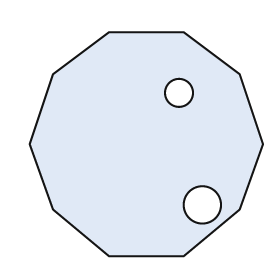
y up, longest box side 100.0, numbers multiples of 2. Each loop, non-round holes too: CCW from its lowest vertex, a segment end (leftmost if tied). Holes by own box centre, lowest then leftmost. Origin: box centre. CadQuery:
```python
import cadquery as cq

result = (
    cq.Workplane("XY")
    .moveTo(-16.0, -48.0)
    .lineTo(16.0, -48.0)
    .lineTo(40.0, -28.0)
    .lineTo(50.0, 0.0)
    .lineTo(40.0, 30.0)
    .lineTo(16.0, 48.0)
    .lineTo(-16.0, 48.0)
    .lineTo(-40.0, 30.0)
    .lineTo(-50.0, 0.0)
    .lineTo(-40.0, -28.0)
    .close()
    .moveTo(24.0, -26.0)
    .circle(8.0)
    .moveTo(14.0, 22.0)
    .circle(6.0)
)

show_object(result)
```